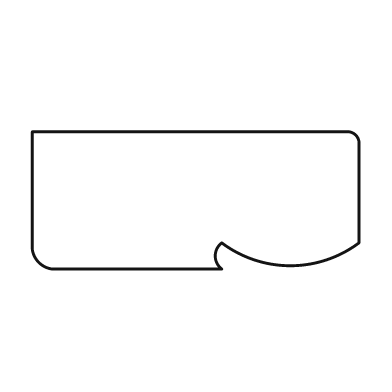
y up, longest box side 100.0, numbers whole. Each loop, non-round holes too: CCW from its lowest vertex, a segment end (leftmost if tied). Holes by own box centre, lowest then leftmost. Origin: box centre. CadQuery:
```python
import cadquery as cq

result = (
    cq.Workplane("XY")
    .moveTo(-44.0, -21.0)
    .lineTo(8.0, -21.0)
    .threePointArc((6.0, -17.0), (8.0, -13.0))
    .threePointArc((29.0, -20.0), (50.0, -13.0))
    .lineTo(50.0, 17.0)
    .threePointArc((49.0, 20.0), (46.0, 21.0))
    .lineTo(-50.0, 21.0)
    .lineTo(-50.0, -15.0)
    .threePointArc((-48.0, -19.0), (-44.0, -21.0))
    .close()
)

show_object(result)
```